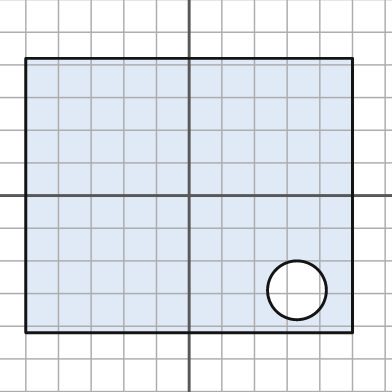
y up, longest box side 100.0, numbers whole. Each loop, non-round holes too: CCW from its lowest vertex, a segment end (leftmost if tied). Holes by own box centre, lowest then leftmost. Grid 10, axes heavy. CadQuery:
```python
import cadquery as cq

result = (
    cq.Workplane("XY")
    .moveTo(-50.0, -42.0)
    .lineTo(50.0, -42.0)
    .lineTo(50.0, 42.0)
    .lineTo(-50.0, 42.0)
    .close()
    .moveTo(33.0, -29.0)
    .circle(9.0)
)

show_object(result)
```